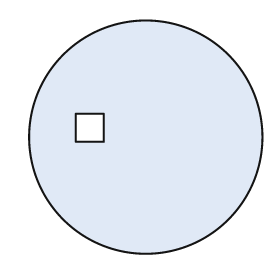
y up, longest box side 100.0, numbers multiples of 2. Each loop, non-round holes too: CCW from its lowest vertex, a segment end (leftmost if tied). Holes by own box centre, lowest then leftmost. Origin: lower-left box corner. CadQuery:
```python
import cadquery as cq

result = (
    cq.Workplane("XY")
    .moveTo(50.0, 50.0)
    .circle(50.0)
    .moveTo(20.0, 48.0)
    .lineTo(32.0, 48.0)
    .lineTo(32.0, 60.0)
    .lineTo(20.0, 60.0)
    .close()
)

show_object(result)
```